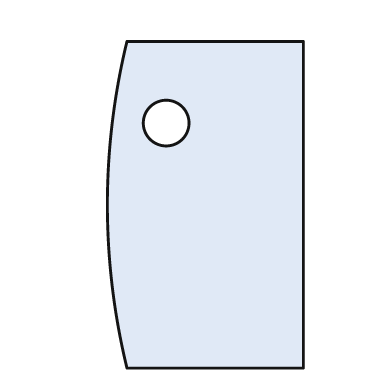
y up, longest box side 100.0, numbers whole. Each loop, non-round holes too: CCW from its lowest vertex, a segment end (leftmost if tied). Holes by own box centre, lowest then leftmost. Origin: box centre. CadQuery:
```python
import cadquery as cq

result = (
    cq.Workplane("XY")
    .moveTo(-24.0, -50.0)
    .lineTo(30.0, -50.0)
    .lineTo(30.0, 50.0)
    .lineTo(-24.0, 50.0)
    .threePointArc((-30.0, 0.0), (-24.0, -50.0))
    .close()
    .moveTo(-12.0, 25.0)
    .circle(7.0)
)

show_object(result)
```